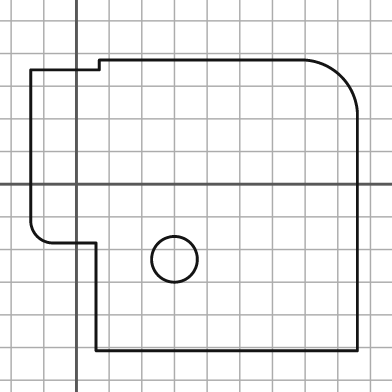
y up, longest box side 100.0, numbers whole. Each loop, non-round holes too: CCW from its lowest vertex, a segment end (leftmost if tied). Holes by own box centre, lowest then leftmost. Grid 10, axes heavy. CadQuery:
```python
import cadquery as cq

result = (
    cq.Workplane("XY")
    .moveTo(6.0, -51.0)
    .lineTo(86.0, -51.0)
    .lineTo(86.0, 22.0)
    .threePointArc((81.0, 33.0), (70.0, 38.0))
    .lineTo(7.0, 38.0)
    .lineTo(7.0, 35.0)
    .lineTo(-14.0, 35.0)
    .lineTo(-14.0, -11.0)
    .threePointArc((-12.0, -16.0), (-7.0, -18.0))
    .lineTo(6.0, -18.0)
    .close()
    .moveTo(30.0, -23.0)
    .circle(7.0)
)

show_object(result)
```